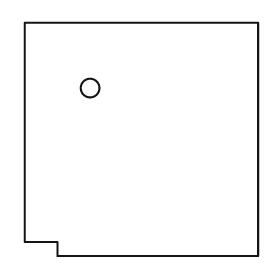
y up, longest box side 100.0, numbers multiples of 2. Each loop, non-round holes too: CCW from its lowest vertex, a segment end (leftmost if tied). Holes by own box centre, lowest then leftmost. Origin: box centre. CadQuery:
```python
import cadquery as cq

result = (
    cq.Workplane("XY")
    .moveTo(-36.0, -50.0)
    .lineTo(50.0, -50.0)
    .lineTo(50.0, 50.0)
    .lineTo(-50.0, 50.0)
    .lineTo(-50.0, -44.0)
    .lineTo(-36.0, -44.0)
    .close()
    .moveTo(-22.0, 22.0)
    .circle(4.0)
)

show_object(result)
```